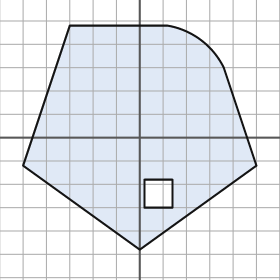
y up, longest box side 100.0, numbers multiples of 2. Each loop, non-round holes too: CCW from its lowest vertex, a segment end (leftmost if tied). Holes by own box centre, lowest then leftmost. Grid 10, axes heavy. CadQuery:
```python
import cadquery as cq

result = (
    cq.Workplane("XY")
    .moveTo(0.0, -48.0)
    .lineTo(50.0, -12.0)
    .lineTo(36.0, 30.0)
    .threePointArc((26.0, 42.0), (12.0, 48.0))
    .lineTo(-30.0, 48.0)
    .lineTo(-50.0, -12.0)
    .close()
    .moveTo(2.0, -30.0)
    .lineTo(14.0, -30.0)
    .lineTo(14.0, -18.0)
    .lineTo(2.0, -18.0)
    .close()
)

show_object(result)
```